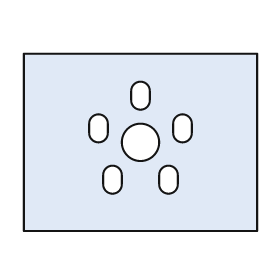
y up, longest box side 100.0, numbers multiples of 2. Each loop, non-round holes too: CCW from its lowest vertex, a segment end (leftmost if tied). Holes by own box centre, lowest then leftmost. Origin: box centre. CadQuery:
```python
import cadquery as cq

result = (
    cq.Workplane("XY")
    .moveTo(-50.0, -38.0)
    .lineTo(50.0, -38.0)
    .lineTo(50.0, 38.0)
    .lineTo(-50.0, 38.0)
    .close()
    .moveTo(-16.0, -18.0)
    .threePointArc((-12.0, -22.0), (-8.0, -18.0))
    .lineTo(-8.0, -14.0)
    .threePointArc((-12.0, -10.0), (-16.0, -14.0))
    .close()
    .moveTo(8.0, -18.0)
    .threePointArc((12.0, -22.0), (16.0, -18.0))
    .lineTo(16.0, -14.0)
    .threePointArc((12.0, -10.0), (8.0, -14.0))
    .close()
    .moveTo(0.0, 0.0)
    .circle(8.0)
    .moveTo(-22.0, 4.0)
    .threePointArc((-18.0, 0.0), (-14.0, 4.0))
    .lineTo(-14.0, 8.0)
    .threePointArc((-18.0, 12.0), (-22.0, 8.0))
    .close()
    .moveTo(14.0, 4.0)
    .threePointArc((18.0, 0.0), (22.0, 4.0))
    .lineTo(22.0, 8.0)
    .threePointArc((18.0, 12.0), (14.0, 8.0))
    .close()
    .moveTo(-4.0, 18.0)
    .threePointArc((0.0, 14.0), (4.0, 18.0))
    .lineTo(4.0, 22.0)
    .threePointArc((0.0, 26.0), (-4.0, 22.0))
    .close()
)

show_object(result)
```